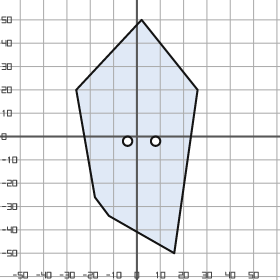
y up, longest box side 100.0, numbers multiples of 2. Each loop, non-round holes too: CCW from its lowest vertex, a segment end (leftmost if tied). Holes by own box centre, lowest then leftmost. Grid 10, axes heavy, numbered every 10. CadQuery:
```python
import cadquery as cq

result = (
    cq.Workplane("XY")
    .moveTo(16.0, -50.0)
    .lineTo(26.0, 20.0)
    .lineTo(2.0, 50.0)
    .lineTo(-26.0, 20.0)
    .lineTo(-18.0, -26.0)
    .lineTo(-12.0, -34.0)
    .close()
    .moveTo(-4.0, -2.0)
    .circle(2.0)
    .moveTo(8.0, -2.0)
    .circle(2.0)
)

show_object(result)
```